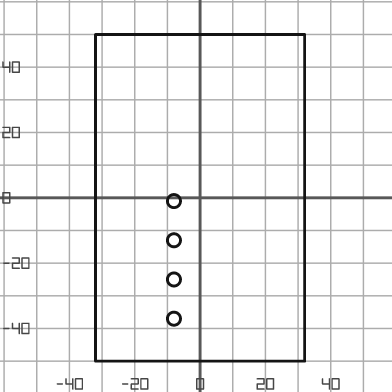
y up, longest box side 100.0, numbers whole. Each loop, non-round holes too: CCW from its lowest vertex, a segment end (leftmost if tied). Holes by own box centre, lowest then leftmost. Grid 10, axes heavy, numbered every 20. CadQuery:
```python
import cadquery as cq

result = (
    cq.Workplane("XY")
    .moveTo(-32.0, -50.0)
    .lineTo(32.0, -50.0)
    .lineTo(32.0, 50.0)
    .lineTo(-32.0, 50.0)
    .close()
    .moveTo(-8.0, -37.0)
    .circle(2.0)
    .moveTo(-8.0, -25.0)
    .circle(2.0)
    .moveTo(-8.0, -13.0)
    .circle(2.0)
    .moveTo(-8.0, -1.0)
    .circle(2.0)
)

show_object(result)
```